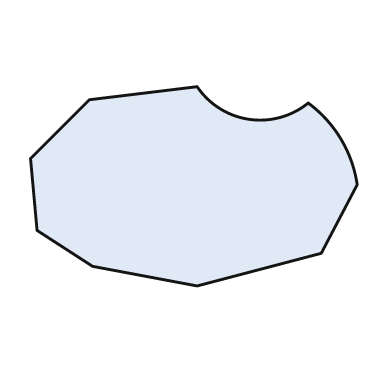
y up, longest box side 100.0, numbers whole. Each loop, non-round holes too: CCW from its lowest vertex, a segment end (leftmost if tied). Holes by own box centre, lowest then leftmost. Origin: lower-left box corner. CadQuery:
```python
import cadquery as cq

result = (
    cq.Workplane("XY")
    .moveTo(51.0, 0.0)
    .lineTo(89.0, 10.0)
    .lineTo(100.0, 31.0)
    .threePointArc((95.0, 45.0), (85.0, 56.0))
    .threePointArc((67.0, 51.0), (51.0, 61.0))
    .lineTo(18.0, 57.0)
    .lineTo(0.0, 39.0)
    .lineTo(2.0, 17.0)
    .lineTo(19.0, 6.0)
    .close()
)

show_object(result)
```